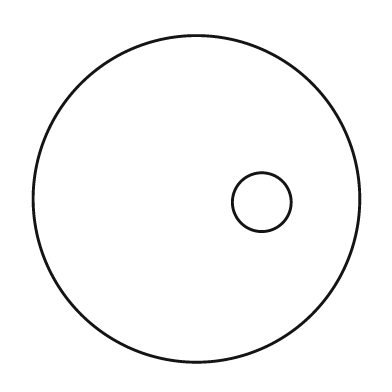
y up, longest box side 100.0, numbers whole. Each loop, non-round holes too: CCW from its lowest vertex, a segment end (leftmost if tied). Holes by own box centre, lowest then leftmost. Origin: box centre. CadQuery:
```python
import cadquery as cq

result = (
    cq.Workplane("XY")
    .moveTo(0.0, 0.0)
    .circle(50.0)
    .moveTo(20.0, -1.0)
    .circle(9.0)
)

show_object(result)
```